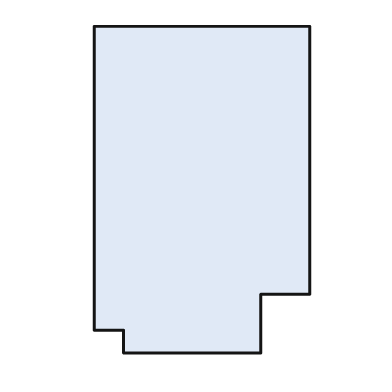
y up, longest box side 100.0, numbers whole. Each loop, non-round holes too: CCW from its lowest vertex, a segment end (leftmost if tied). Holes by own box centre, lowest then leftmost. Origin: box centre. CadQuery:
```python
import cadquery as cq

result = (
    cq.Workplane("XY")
    .moveTo(-24.0, -50.0)
    .lineTo(18.0, -50.0)
    .lineTo(18.0, -32.0)
    .lineTo(33.0, -32.0)
    .lineTo(33.0, 50.0)
    .lineTo(-33.0, 50.0)
    .lineTo(-33.0, -43.0)
    .lineTo(-24.0, -43.0)
    .close()
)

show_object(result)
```